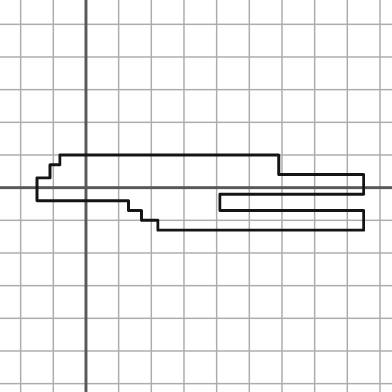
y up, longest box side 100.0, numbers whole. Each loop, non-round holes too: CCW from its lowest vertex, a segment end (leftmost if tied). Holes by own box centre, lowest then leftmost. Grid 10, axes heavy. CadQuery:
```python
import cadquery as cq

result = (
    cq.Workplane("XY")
    .moveTo(22.0, -13.0)
    .lineTo(85.0, -13.0)
    .lineTo(85.0, -7.0)
    .lineTo(41.0, -7.0)
    .lineTo(41.0, -2.0)
    .lineTo(85.0, -2.0)
    .lineTo(85.0, 4.0)
    .lineTo(59.0, 4.0)
    .lineTo(59.0, 10.0)
    .lineTo(-8.0, 10.0)
    .lineTo(-8.0, 7.0)
    .lineTo(-11.0, 7.0)
    .lineTo(-11.0, 3.0)
    .lineTo(-15.0, 3.0)
    .lineTo(-15.0, -4.0)
    .lineTo(13.0, -4.0)
    .lineTo(13.0, -7.0)
    .lineTo(17.0, -7.0)
    .lineTo(17.0, -10.0)
    .lineTo(22.0, -10.0)
    .close()
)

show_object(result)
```